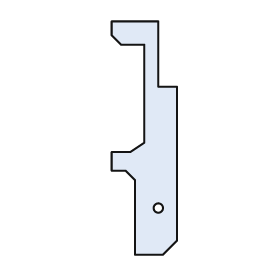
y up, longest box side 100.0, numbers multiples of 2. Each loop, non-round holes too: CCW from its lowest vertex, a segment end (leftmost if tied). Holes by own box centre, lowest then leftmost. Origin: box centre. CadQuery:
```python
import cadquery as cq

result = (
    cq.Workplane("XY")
    .moveTo(-4.0, -50.0)
    .lineTo(8.0, -50.0)
    .lineTo(14.0, -44.0)
    .lineTo(14.0, 22.0)
    .lineTo(6.0, 22.0)
    .lineTo(6.0, 50.0)
    .lineTo(-14.0, 50.0)
    .lineTo(-14.0, 44.0)
    .lineTo(-10.0, 40.0)
    .lineTo(0.0, 40.0)
    .lineTo(0.0, -2.0)
    .lineTo(-6.0, -6.0)
    .lineTo(-14.0, -6.0)
    .lineTo(-14.0, -14.0)
    .lineTo(-8.0, -14.0)
    .lineTo(-4.0, -18.0)
    .close()
    .moveTo(6.0, -30.0)
    .circle(2.0)
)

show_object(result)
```